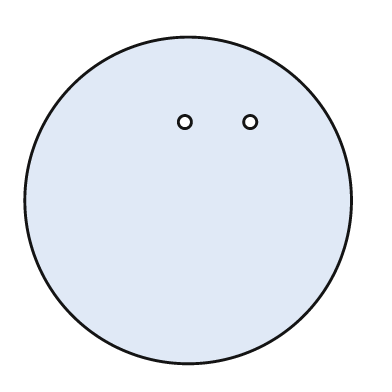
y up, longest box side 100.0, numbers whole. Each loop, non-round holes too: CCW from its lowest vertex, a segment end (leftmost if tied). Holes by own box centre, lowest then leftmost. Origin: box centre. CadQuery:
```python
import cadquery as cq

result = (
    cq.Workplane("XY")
    .moveTo(0.0, 0.0)
    .circle(50.0)
    .moveTo(-1.0, 24.0)
    .circle(2.0)
    .moveTo(19.0, 24.0)
    .circle(2.0)
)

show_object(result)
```